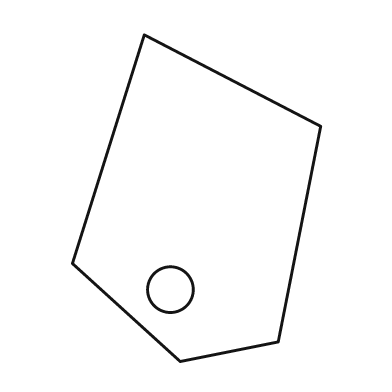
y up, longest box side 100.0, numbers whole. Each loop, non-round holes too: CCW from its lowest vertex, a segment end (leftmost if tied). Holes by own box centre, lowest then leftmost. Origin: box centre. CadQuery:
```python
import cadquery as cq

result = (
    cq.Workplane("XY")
    .moveTo(-5.0, -50.0)
    .lineTo(25.0, -44.0)
    .lineTo(38.0, 22.0)
    .lineTo(-16.0, 50.0)
    .lineTo(-38.0, -20.0)
    .close()
    .moveTo(-8.0, -28.0)
    .circle(7.0)
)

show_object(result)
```